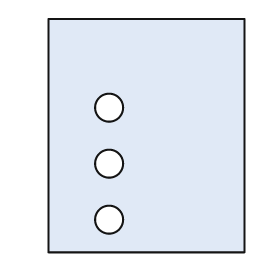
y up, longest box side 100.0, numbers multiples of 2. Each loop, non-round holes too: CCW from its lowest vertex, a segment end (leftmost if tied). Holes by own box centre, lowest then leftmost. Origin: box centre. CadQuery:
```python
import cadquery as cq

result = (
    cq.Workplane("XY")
    .moveTo(-42.0, -50.0)
    .lineTo(42.0, -50.0)
    .lineTo(42.0, 50.0)
    .lineTo(-42.0, 50.0)
    .close()
    .moveTo(-16.0, -36.0)
    .circle(6.0)
    .moveTo(-16.0, -12.0)
    .circle(6.0)
    .moveTo(-16.0, 12.0)
    .circle(6.0)
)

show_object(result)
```